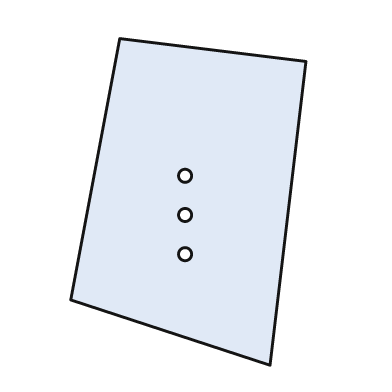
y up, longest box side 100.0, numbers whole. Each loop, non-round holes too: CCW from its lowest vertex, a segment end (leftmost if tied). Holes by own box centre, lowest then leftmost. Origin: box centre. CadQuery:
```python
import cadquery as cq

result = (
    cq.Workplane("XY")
    .moveTo(25.0, -50.0)
    .lineTo(36.0, 43.0)
    .lineTo(-21.0, 50.0)
    .lineTo(-36.0, -30.0)
    .close()
    .moveTo(-1.0, -16.0)
    .circle(2.0)
    .moveTo(-1.0, -4.0)
    .circle(2.0)
    .moveTo(-1.0, 8.0)
    .circle(2.0)
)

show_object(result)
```